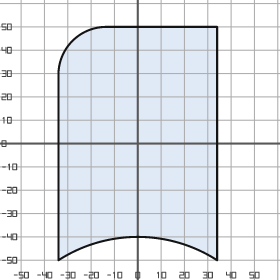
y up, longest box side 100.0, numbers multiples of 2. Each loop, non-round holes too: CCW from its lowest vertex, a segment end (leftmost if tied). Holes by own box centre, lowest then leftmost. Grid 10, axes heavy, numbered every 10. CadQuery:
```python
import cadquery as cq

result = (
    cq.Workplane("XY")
    .moveTo(-34.0, -50.0)
    .threePointArc((0.0, -40.0), (34.0, -50.0))
    .lineTo(34.0, 50.0)
    .lineTo(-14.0, 50.0)
    .threePointArc((-28.0, 44.0), (-34.0, 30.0))
    .close()
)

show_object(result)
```